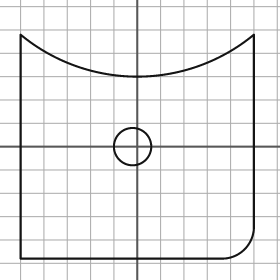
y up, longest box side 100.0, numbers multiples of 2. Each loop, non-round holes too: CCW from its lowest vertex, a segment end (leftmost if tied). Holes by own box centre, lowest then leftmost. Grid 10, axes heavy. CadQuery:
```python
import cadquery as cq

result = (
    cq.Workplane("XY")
    .moveTo(-50.0, -48.0)
    .lineTo(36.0, -48.0)
    .threePointArc((46.0, -44.0), (50.0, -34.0))
    .lineTo(50.0, 48.0)
    .threePointArc((0.0, 30.0), (-50.0, 48.0))
    .close()
    .moveTo(-2.0, 0.0)
    .circle(8.0)
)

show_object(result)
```